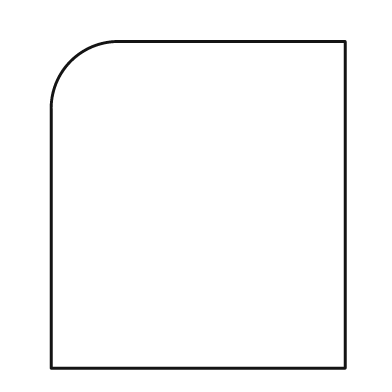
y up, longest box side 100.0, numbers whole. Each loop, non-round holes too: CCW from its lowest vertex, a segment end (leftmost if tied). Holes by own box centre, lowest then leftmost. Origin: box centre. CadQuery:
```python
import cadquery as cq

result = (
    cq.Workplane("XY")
    .moveTo(-45.0, -50.0)
    .lineTo(45.0, -50.0)
    .lineTo(45.0, 50.0)
    .lineTo(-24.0, 50.0)
    .threePointArc((-39.0, 44.0), (-45.0, 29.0))
    .close()
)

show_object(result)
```